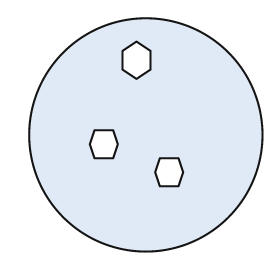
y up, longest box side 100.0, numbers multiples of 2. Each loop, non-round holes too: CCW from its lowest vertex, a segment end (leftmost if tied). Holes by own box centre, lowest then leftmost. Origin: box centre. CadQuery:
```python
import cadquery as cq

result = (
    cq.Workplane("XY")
    .moveTo(0.0, 0.0)
    .circle(50.0)
    .moveTo(6.0, -22.0)
    .lineTo(14.0, -22.0)
    .lineTo(16.0, -16.0)
    .lineTo(14.0, -10.0)
    .lineTo(6.0, -10.0)
    .lineTo(4.0, -16.0)
    .close()
    .moveTo(-22.0, -10.0)
    .lineTo(-14.0, -10.0)
    .lineTo(-12.0, -4.0)
    .lineTo(-14.0, 2.0)
    .lineTo(-22.0, 2.0)
    .lineTo(-24.0, -4.0)
    .close()
    .moveTo(-4.0, 24.0)
    .lineTo(2.0, 28.0)
    .lineTo(2.0, 36.0)
    .lineTo(-4.0, 40.0)
    .lineTo(-10.0, 36.0)
    .lineTo(-10.0, 28.0)
    .close()
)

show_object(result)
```